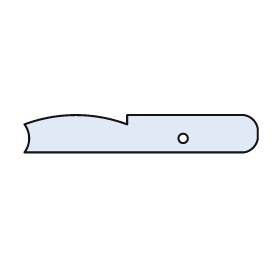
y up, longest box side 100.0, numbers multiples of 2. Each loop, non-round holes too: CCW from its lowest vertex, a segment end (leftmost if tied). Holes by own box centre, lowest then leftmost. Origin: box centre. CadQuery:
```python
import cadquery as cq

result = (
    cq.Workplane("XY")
    .moveTo(-50.0, -8.0)
    .lineTo(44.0, -8.0)
    .threePointArc((48.0, -6.0), (50.0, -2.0))
    .lineTo(50.0, 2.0)
    .threePointArc((48.0, 6.0), (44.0, 8.0))
    .lineTo(-6.0, 8.0)
    .lineTo(-6.0, 4.0)
    .threePointArc((-28.0, 8.0), (-50.0, 4.0))
    .threePointArc((-48.0, -2.0), (-50.0, -8.0))
    .close()
    .moveTo(18.0, -2.0)
    .circle(2.0)
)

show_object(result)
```